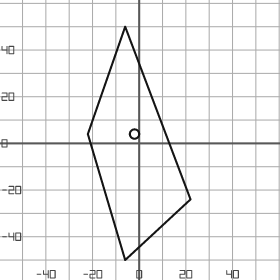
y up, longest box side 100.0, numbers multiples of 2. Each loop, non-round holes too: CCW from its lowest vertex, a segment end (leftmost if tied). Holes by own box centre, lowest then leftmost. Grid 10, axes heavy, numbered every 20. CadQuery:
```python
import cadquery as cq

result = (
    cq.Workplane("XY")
    .moveTo(-6.0, -50.0)
    .lineTo(22.0, -24.0)
    .lineTo(-6.0, 50.0)
    .lineTo(-22.0, 4.0)
    .close()
    .moveTo(-2.0, 4.0)
    .circle(2.0)
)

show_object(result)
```